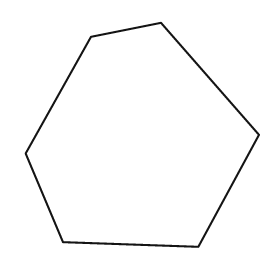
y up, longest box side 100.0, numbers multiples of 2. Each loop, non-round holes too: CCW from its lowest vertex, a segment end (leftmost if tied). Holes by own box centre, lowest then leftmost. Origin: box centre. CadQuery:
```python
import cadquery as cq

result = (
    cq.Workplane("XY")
    .moveTo(24.0, -48.0)
    .lineTo(50.0, 0.0)
    .lineTo(8.0, 48.0)
    .lineTo(-22.0, 42.0)
    .lineTo(-50.0, -8.0)
    .lineTo(-34.0, -46.0)
    .close()
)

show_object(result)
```